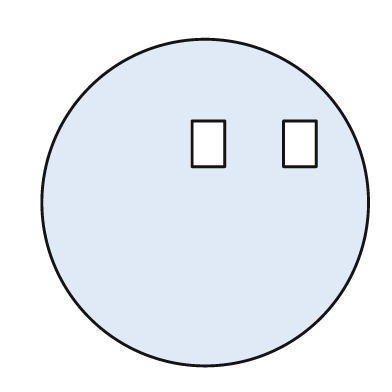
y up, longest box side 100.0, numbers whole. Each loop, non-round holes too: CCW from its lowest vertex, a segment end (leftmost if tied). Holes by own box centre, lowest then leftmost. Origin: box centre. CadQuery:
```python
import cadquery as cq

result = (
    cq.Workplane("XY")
    .moveTo(0.0, 0.0)
    .circle(50.0)
    .moveTo(-4.0, 11.0)
    .lineTo(6.0, 11.0)
    .lineTo(6.0, 25.0)
    .lineTo(-4.0, 25.0)
    .close()
    .moveTo(24.0, 11.0)
    .lineTo(34.0, 11.0)
    .lineTo(34.0, 25.0)
    .lineTo(24.0, 25.0)
    .close()
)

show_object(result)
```